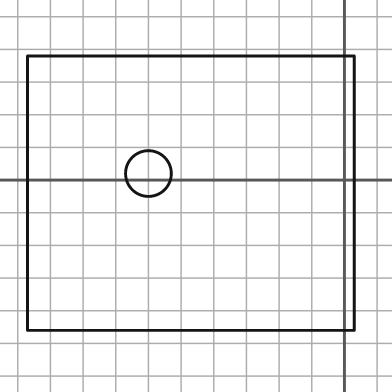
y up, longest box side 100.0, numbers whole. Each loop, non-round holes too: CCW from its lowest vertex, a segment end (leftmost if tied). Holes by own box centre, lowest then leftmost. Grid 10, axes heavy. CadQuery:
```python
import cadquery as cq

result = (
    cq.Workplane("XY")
    .moveTo(-97.0, -46.0)
    .lineTo(3.0, -46.0)
    .lineTo(3.0, 38.0)
    .lineTo(-97.0, 38.0)
    .close()
    .moveTo(-60.0, 2.0)
    .circle(7.0)
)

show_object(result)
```